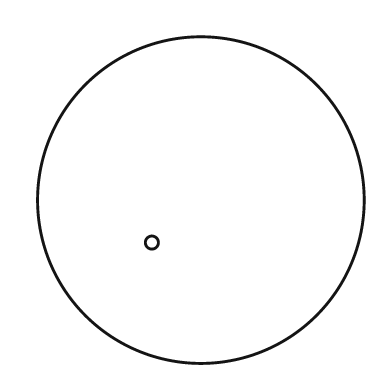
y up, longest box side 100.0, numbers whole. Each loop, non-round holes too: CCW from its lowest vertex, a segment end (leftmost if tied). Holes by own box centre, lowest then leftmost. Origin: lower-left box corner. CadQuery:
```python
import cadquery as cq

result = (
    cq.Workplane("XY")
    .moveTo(50.0, 50.0)
    .circle(50.0)
    .moveTo(35.0, 37.0)
    .circle(2.0)
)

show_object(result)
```